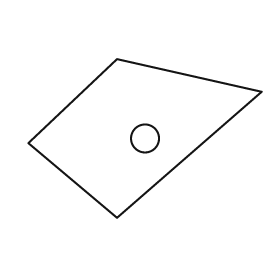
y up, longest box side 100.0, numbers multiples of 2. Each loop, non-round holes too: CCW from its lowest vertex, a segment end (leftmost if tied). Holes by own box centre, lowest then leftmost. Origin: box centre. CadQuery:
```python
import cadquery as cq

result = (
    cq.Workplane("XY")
    .moveTo(-12.0, -34.0)
    .lineTo(50.0, 20.0)
    .lineTo(-12.0, 34.0)
    .lineTo(-50.0, -2.0)
    .close()
    .moveTo(0.0, 0.0)
    .circle(6.0)
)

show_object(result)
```